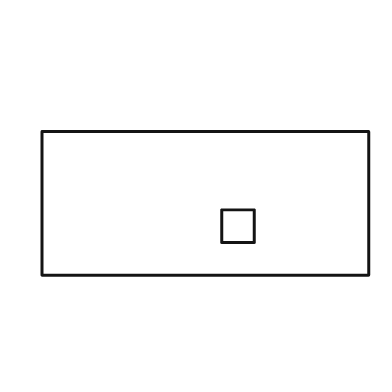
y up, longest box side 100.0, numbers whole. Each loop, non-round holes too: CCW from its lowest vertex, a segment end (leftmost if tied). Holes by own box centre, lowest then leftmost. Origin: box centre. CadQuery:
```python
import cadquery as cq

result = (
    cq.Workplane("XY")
    .moveTo(-50.0, -22.0)
    .lineTo(50.0, -22.0)
    .lineTo(50.0, 22.0)
    .lineTo(-50.0, 22.0)
    .close()
    .moveTo(5.0, -12.0)
    .lineTo(15.0, -12.0)
    .lineTo(15.0, -2.0)
    .lineTo(5.0, -2.0)
    .close()
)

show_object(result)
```